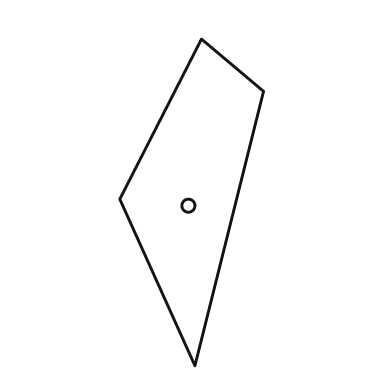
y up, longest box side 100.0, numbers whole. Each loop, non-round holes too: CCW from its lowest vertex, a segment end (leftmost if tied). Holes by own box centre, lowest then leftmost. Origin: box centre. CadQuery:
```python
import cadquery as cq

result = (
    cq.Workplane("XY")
    .moveTo(1.0, -50.0)
    .lineTo(22.0, 34.0)
    .lineTo(3.0, 50.0)
    .lineTo(-22.0, 1.0)
    .close()
    .moveTo(-1.0, -1.0)
    .circle(2.0)
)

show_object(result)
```